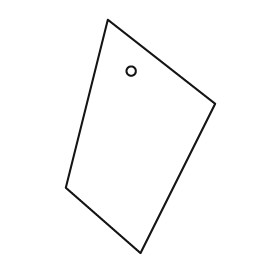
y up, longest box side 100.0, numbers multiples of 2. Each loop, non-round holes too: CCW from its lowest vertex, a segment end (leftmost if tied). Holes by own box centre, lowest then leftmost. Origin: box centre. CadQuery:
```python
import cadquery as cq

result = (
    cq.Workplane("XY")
    .moveTo(0.0, -50.0)
    .lineTo(32.0, 14.0)
    .lineTo(-14.0, 50.0)
    .lineTo(-32.0, -22.0)
    .close()
    .moveTo(-4.0, 28.0)
    .circle(2.0)
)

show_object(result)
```